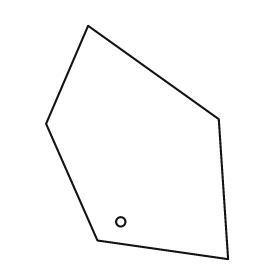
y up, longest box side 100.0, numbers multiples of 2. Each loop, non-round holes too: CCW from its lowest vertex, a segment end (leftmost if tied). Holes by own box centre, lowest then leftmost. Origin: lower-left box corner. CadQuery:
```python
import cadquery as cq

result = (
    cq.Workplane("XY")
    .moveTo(78.0, 0.0)
    .lineTo(74.0, 60.0)
    .lineTo(18.0, 100.0)
    .lineTo(0.0, 58.0)
    .lineTo(22.0, 8.0)
    .close()
    .moveTo(32.0, 16.0)
    .circle(2.0)
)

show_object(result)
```